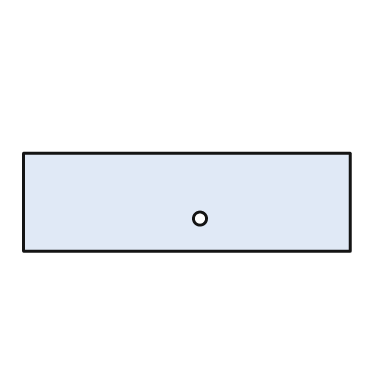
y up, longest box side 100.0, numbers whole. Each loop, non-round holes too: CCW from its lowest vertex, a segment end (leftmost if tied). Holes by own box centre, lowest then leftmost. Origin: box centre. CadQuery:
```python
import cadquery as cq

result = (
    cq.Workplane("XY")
    .moveTo(-50.0, -15.0)
    .lineTo(50.0, -15.0)
    .lineTo(50.0, 15.0)
    .lineTo(-50.0, 15.0)
    .close()
    .moveTo(4.0, -5.0)
    .circle(2.0)
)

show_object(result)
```